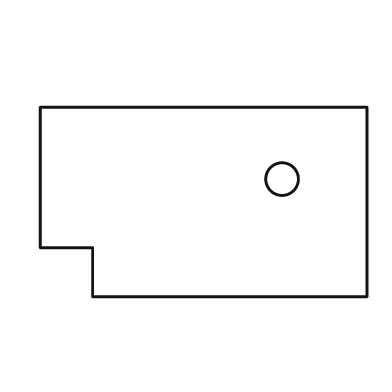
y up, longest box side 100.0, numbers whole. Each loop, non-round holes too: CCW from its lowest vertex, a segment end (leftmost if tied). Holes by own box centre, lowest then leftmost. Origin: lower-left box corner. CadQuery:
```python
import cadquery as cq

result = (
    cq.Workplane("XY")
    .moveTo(16.0, 0.0)
    .lineTo(100.0, 0.0)
    .lineTo(100.0, 58.0)
    .lineTo(0.0, 58.0)
    .lineTo(0.0, 15.0)
    .lineTo(16.0, 15.0)
    .close()
    .moveTo(74.0, 36.0)
    .circle(5.0)
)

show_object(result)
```